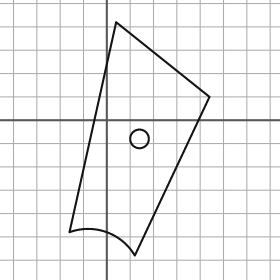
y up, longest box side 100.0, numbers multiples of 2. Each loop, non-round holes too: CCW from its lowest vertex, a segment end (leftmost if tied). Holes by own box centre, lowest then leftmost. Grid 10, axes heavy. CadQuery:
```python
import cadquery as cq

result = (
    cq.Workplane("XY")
    .moveTo(12.0, -58.0)
    .lineTo(44.0, 10.0)
    .lineTo(4.0, 42.0)
    .lineTo(-16.0, -48.0)
    .threePointArc((0.0, -48.0), (12.0, -58.0))
    .close()
    .moveTo(14.0, -8.0)
    .circle(4.0)
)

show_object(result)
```